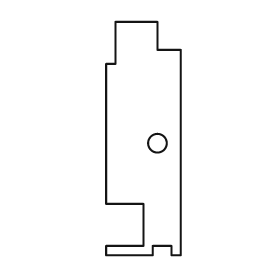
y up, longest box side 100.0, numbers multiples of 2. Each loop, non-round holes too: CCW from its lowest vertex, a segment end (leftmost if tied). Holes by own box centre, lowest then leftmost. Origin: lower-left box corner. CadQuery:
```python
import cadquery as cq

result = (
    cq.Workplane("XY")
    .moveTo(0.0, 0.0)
    .lineTo(20.0, 0.0)
    .lineTo(20.0, 4.0)
    .lineTo(28.0, 4.0)
    .lineTo(28.0, 0.0)
    .lineTo(32.0, 0.0)
    .lineTo(32.0, 88.0)
    .lineTo(22.0, 88.0)
    .lineTo(22.0, 100.0)
    .lineTo(4.0, 100.0)
    .lineTo(4.0, 82.0)
    .lineTo(0.0, 82.0)
    .lineTo(0.0, 22.0)
    .lineTo(16.0, 22.0)
    .lineTo(16.0, 4.0)
    .lineTo(0.0, 4.0)
    .close()
    .moveTo(22.0, 48.0)
    .circle(4.0)
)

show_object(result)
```